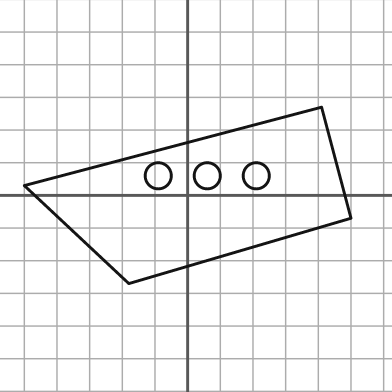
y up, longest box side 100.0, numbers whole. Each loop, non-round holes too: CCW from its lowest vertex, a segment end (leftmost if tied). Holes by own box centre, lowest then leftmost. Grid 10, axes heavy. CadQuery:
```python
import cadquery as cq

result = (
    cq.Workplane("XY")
    .moveTo(-18.0, -27.0)
    .lineTo(50.0, -7.0)
    .lineTo(41.0, 27.0)
    .lineTo(-50.0, 3.0)
    .close()
    .moveTo(-9.0, 6.0)
    .circle(4.0)
    .moveTo(6.0, 6.0)
    .circle(4.0)
    .moveTo(21.0, 6.0)
    .circle(4.0)
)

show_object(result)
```